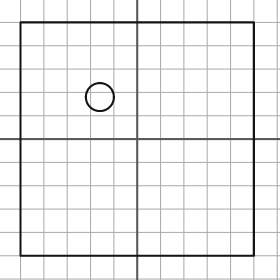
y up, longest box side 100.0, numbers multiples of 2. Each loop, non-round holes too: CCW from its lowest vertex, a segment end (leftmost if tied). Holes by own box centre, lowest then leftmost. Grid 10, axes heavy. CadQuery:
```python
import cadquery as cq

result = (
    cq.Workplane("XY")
    .moveTo(-50.0, -50.0)
    .lineTo(50.0, -50.0)
    .lineTo(50.0, 50.0)
    .lineTo(-50.0, 50.0)
    .close()
    .moveTo(-16.0, 18.0)
    .circle(6.0)
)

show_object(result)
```